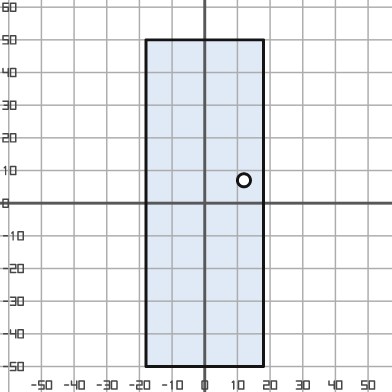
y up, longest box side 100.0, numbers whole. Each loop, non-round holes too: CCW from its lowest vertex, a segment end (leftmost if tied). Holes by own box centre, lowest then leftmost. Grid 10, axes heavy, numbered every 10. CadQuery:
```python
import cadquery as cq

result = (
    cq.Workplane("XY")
    .moveTo(-18.0, -50.0)
    .lineTo(18.0, -50.0)
    .lineTo(18.0, 50.0)
    .lineTo(-18.0, 50.0)
    .close()
    .moveTo(12.0, 7.0)
    .circle(2.0)
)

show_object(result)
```